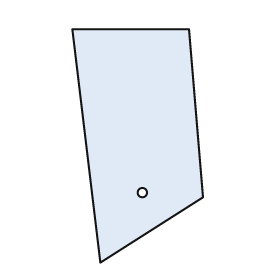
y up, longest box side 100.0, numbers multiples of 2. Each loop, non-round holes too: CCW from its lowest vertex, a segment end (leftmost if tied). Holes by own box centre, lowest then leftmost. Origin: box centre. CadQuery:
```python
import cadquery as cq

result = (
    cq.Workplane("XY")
    .moveTo(-16.0, -50.0)
    .lineTo(28.0, -22.0)
    .lineTo(22.0, 50.0)
    .lineTo(-28.0, 50.0)
    .close()
    .moveTo(2.0, -20.0)
    .circle(2.0)
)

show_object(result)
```